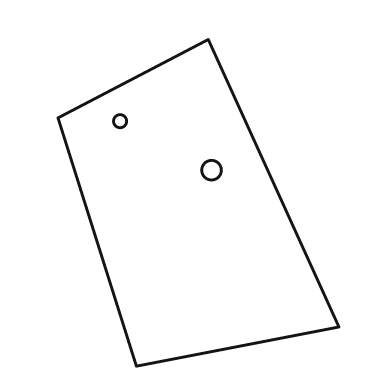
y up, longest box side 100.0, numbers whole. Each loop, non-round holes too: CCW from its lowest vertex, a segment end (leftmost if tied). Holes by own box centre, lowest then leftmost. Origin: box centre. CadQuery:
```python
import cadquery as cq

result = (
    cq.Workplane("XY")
    .moveTo(-19.0, -50.0)
    .lineTo(43.0, -38.0)
    .lineTo(3.0, 50.0)
    .lineTo(-43.0, 26.0)
    .close()
    .moveTo(4.0, 10.0)
    .circle(3.0)
    .moveTo(-24.0, 25.0)
    .circle(2.0)
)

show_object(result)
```